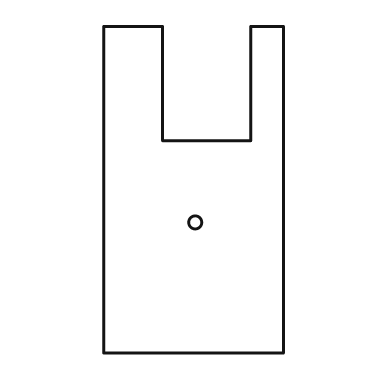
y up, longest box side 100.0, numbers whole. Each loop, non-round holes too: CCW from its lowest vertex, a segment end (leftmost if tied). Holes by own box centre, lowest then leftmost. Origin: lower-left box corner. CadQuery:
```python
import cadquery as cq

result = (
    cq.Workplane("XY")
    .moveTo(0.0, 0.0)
    .lineTo(55.0, 0.0)
    .lineTo(55.0, 100.0)
    .lineTo(45.0, 100.0)
    .lineTo(45.0, 65.0)
    .lineTo(18.0, 65.0)
    .lineTo(18.0, 100.0)
    .lineTo(0.0, 100.0)
    .close()
    .moveTo(28.0, 40.0)
    .circle(2.0)
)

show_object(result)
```